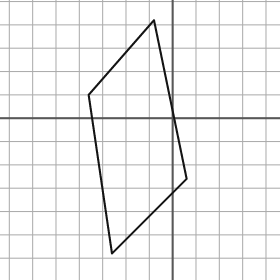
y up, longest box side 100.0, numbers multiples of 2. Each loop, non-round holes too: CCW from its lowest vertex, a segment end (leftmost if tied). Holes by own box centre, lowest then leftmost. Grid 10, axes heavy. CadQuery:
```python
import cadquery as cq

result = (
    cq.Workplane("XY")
    .moveTo(-26.0, -58.0)
    .lineTo(6.0, -26.0)
    .lineTo(-8.0, 42.0)
    .lineTo(-36.0, 10.0)
    .close()
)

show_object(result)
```